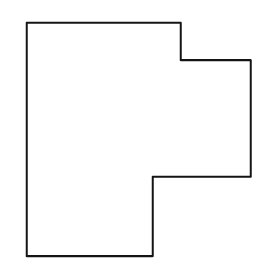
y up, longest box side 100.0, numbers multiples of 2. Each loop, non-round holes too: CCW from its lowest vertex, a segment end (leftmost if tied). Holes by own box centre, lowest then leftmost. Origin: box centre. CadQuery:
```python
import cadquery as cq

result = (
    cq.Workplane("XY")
    .moveTo(-48.0, -50.0)
    .lineTo(6.0, -50.0)
    .lineTo(6.0, -16.0)
    .lineTo(48.0, -16.0)
    .lineTo(48.0, 34.0)
    .lineTo(18.0, 34.0)
    .lineTo(18.0, 50.0)
    .lineTo(-48.0, 50.0)
    .close()
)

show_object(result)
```